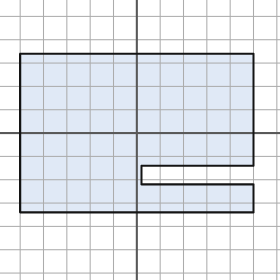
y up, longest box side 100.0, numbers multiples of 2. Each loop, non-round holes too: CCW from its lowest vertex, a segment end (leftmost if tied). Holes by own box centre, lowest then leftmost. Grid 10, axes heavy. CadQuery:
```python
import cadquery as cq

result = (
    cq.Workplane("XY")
    .moveTo(-50.0, -34.0)
    .lineTo(50.0, -34.0)
    .lineTo(50.0, -22.0)
    .lineTo(2.0, -22.0)
    .lineTo(2.0, -14.0)
    .lineTo(50.0, -14.0)
    .lineTo(50.0, 34.0)
    .lineTo(-50.0, 34.0)
    .close()
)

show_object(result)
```